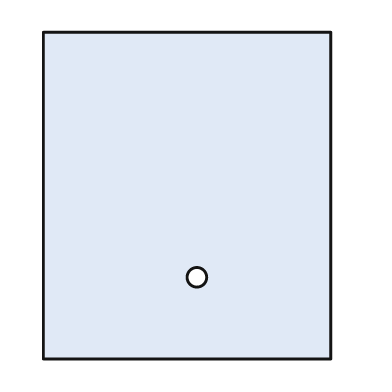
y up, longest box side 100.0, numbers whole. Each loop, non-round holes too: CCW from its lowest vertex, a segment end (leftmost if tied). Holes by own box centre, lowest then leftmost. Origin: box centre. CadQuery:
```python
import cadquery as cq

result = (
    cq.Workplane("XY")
    .moveTo(-44.0, -50.0)
    .lineTo(44.0, -50.0)
    .lineTo(44.0, 50.0)
    .lineTo(-44.0, 50.0)
    .close()
    .moveTo(3.0, -25.0)
    .circle(3.0)
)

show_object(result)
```